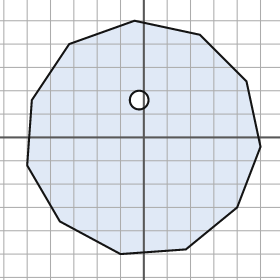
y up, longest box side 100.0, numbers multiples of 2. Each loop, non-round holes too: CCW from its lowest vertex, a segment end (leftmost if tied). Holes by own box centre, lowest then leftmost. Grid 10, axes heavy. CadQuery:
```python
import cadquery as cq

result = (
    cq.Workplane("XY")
    .moveTo(-10.0, -50.0)
    .lineTo(18.0, -48.0)
    .lineTo(40.0, -30.0)
    .lineTo(50.0, -4.0)
    .lineTo(44.0, 24.0)
    .lineTo(24.0, 44.0)
    .lineTo(-4.0, 50.0)
    .lineTo(-32.0, 40.0)
    .lineTo(-48.0, 16.0)
    .lineTo(-50.0, -12.0)
    .lineTo(-36.0, -36.0)
    .close()
    .moveTo(-2.0, 16.0)
    .circle(4.0)
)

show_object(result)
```